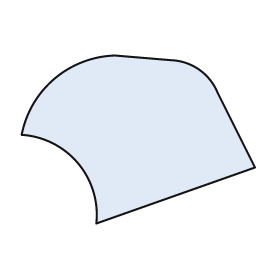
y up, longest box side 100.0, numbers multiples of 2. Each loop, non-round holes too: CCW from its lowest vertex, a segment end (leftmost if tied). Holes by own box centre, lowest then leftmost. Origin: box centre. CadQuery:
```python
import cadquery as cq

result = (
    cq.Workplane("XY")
    .moveTo(-18.0, -36.0)
    .lineTo(50.0, -12.0)
    .lineTo(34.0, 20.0)
    .threePointArc((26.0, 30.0), (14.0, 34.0))
    .lineTo(-10.0, 36.0)
    .threePointArc((-36.0, 26.0), (-50.0, 2.0))
    .threePointArc((-26.0, -10.0), (-18.0, -36.0))
    .close()
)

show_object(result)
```